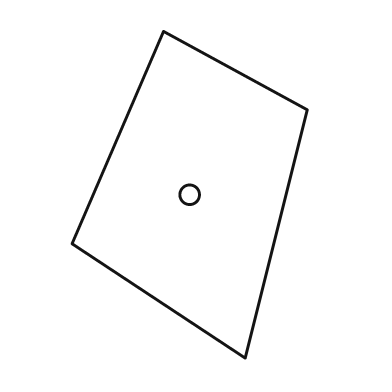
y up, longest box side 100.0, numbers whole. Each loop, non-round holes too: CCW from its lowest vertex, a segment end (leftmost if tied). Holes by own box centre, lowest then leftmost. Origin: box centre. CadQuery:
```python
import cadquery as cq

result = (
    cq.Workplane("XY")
    .moveTo(17.0, -50.0)
    .lineTo(36.0, 26.0)
    .lineTo(-8.0, 50.0)
    .lineTo(-36.0, -15.0)
    .close()
    .moveTo(0.0, 0.0)
    .circle(3.0)
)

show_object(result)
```